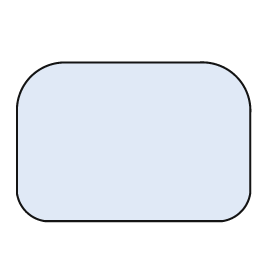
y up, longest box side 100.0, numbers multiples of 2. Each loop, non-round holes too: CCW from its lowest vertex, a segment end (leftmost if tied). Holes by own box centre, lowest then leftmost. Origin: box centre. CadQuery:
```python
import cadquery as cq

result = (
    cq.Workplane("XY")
    .moveTo(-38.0, -34.0)
    .lineTo(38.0, -34.0)
    .threePointArc((46.0, -30.0), (50.0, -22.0))
    .lineTo(50.0, 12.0)
    .threePointArc((44.0, 28.0), (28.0, 34.0))
    .lineTo(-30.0, 34.0)
    .threePointArc((-44.0, 28.0), (-50.0, 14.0))
    .lineTo(-50.0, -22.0)
    .threePointArc((-46.0, -30.0), (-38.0, -34.0))
    .close()
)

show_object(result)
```